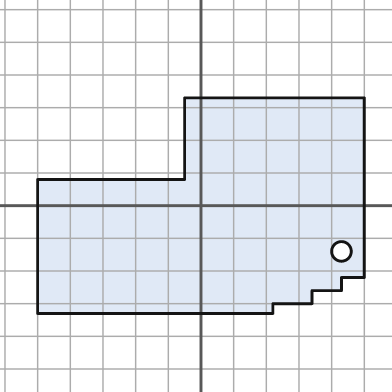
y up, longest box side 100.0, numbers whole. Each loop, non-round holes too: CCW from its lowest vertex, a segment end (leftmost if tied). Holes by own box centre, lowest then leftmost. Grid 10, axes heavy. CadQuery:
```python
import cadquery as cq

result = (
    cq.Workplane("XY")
    .moveTo(-50.0, -33.0)
    .lineTo(22.0, -33.0)
    .lineTo(22.0, -30.0)
    .lineTo(34.0, -30.0)
    .lineTo(34.0, -26.0)
    .lineTo(43.0, -26.0)
    .lineTo(43.0, -22.0)
    .lineTo(50.0, -22.0)
    .lineTo(50.0, 33.0)
    .lineTo(-5.0, 33.0)
    .lineTo(-5.0, 8.0)
    .lineTo(-50.0, 8.0)
    .close()
    .moveTo(43.0, -14.0)
    .circle(3.0)
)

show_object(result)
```